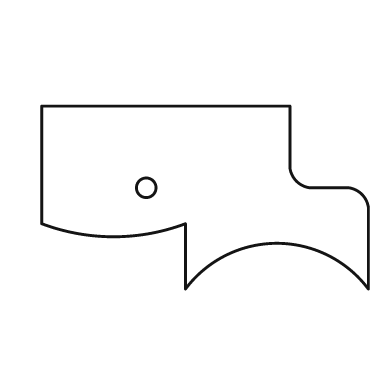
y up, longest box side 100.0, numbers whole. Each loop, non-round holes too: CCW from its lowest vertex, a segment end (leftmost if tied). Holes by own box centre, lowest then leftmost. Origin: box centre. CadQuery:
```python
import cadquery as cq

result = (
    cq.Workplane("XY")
    .moveTo(-6.0, -28.0)
    .threePointArc((22.0, -14.0), (50.0, -28.0))
    .lineTo(50.0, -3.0)
    .threePointArc((48.0, 1.0), (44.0, 3.0))
    .lineTo(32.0, 3.0)
    .threePointArc((28.0, 5.0), (26.0, 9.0))
    .lineTo(26.0, 28.0)
    .lineTo(-50.0, 28.0)
    .lineTo(-50.0, -8.0)
    .threePointArc((-28.0, -12.0), (-6.0, -8.0))
    .close()
    .moveTo(-18.0, 3.0)
    .circle(3.0)
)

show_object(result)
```